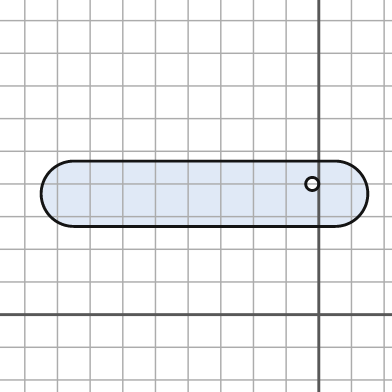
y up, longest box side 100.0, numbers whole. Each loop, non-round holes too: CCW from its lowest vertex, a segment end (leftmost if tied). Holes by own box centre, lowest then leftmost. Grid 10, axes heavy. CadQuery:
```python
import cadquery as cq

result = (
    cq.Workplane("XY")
    .moveTo(-75.0, 27.0)
    .lineTo(5.0, 27.0)
    .threePointArc((15.0, 37.0), (5.0, 47.0))
    .lineTo(-75.0, 47.0)
    .threePointArc((-85.0, 37.0), (-75.0, 27.0))
    .close()
    .moveTo(-2.0, 40.0)
    .circle(2.0)
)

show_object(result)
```